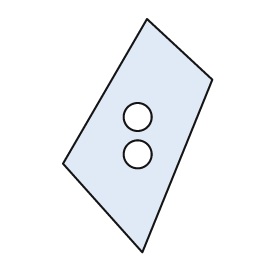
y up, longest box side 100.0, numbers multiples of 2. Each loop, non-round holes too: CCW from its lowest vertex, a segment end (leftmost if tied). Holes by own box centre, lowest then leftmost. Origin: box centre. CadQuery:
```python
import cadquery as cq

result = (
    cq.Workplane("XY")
    .moveTo(2.0, -50.0)
    .lineTo(32.0, 24.0)
    .lineTo(4.0, 50.0)
    .lineTo(-32.0, -12.0)
    .close()
    .moveTo(0.0, -8.0)
    .circle(6.0)
    .moveTo(0.0, 8.0)
    .circle(6.0)
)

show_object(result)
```